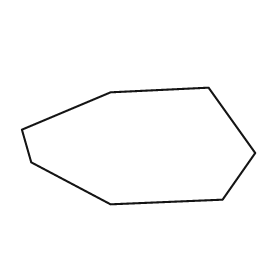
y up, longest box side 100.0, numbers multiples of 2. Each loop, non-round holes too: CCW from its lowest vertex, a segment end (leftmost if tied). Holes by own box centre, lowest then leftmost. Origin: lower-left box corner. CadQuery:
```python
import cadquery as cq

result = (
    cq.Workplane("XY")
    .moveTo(38.0, 0.0)
    .lineTo(86.0, 2.0)
    .lineTo(100.0, 22.0)
    .lineTo(80.0, 50.0)
    .lineTo(38.0, 48.0)
    .lineTo(0.0, 32.0)
    .lineTo(4.0, 18.0)
    .close()
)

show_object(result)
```